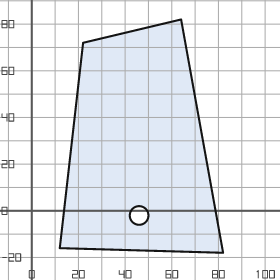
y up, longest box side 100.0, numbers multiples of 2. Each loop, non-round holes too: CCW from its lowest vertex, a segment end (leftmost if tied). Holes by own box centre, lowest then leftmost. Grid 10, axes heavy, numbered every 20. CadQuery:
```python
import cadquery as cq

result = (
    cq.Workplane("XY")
    .moveTo(82.0, -18.0)
    .lineTo(64.0, 82.0)
    .lineTo(22.0, 72.0)
    .lineTo(12.0, -16.0)
    .close()
    .moveTo(46.0, -2.0)
    .circle(4.0)
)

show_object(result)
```